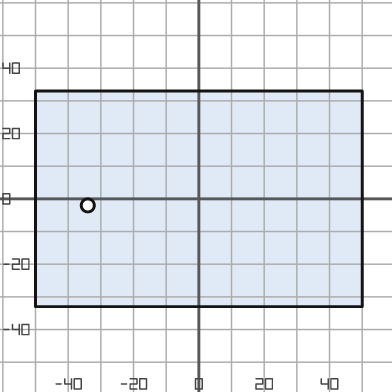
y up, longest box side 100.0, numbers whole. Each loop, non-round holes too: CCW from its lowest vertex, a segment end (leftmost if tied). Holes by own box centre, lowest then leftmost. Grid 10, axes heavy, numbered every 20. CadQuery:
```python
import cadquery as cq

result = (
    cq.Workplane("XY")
    .moveTo(-50.0, -33.0)
    .lineTo(50.0, -33.0)
    .lineTo(50.0, 33.0)
    .lineTo(-50.0, 33.0)
    .close()
    .moveTo(-34.0, -2.0)
    .circle(2.0)
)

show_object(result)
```